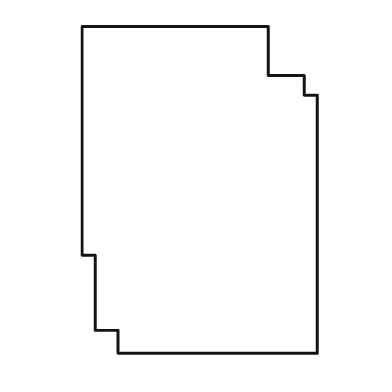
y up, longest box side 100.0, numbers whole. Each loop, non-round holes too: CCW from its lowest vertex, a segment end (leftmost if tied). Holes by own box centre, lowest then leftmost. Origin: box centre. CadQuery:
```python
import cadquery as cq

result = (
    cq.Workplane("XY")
    .moveTo(-25.0, -50.0)
    .lineTo(36.0, -50.0)
    .lineTo(36.0, 29.0)
    .lineTo(32.0, 29.0)
    .lineTo(32.0, 35.0)
    .lineTo(21.0, 35.0)
    .lineTo(21.0, 50.0)
    .lineTo(-36.0, 50.0)
    .lineTo(-36.0, -20.0)
    .lineTo(-32.0, -20.0)
    .lineTo(-32.0, -43.0)
    .lineTo(-25.0, -43.0)
    .close()
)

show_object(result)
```